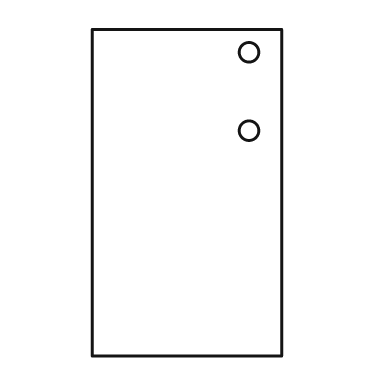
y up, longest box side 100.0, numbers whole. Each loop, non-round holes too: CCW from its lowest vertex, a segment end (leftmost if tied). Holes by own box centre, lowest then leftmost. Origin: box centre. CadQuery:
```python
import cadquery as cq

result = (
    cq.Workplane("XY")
    .moveTo(-29.0, -50.0)
    .lineTo(29.0, -50.0)
    .lineTo(29.0, 50.0)
    .lineTo(-29.0, 50.0)
    .close()
    .moveTo(19.0, 19.0)
    .circle(3.0)
    .moveTo(19.0, 43.0)
    .circle(3.0)
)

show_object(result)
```